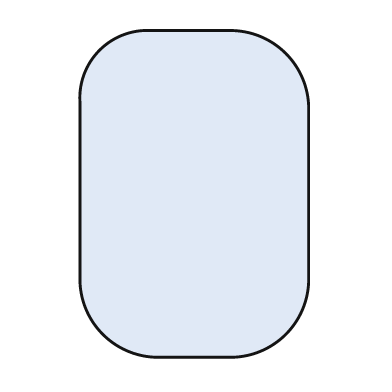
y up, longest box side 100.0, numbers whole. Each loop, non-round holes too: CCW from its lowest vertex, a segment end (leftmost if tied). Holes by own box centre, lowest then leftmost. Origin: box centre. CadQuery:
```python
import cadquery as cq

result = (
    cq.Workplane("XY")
    .moveTo(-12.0, -50.0)
    .lineTo(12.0, -50.0)
    .threePointArc((28.0, -43.0), (35.0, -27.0))
    .lineTo(35.0, 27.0)
    .threePointArc((28.0, 43.0), (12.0, 50.0))
    .lineTo(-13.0, 50.0)
    .threePointArc((-29.0, 44.0), (-35.0, 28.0))
    .lineTo(-35.0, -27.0)
    .threePointArc((-28.0, -43.0), (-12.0, -50.0))
    .close()
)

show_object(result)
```